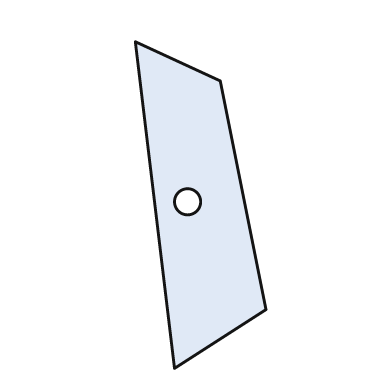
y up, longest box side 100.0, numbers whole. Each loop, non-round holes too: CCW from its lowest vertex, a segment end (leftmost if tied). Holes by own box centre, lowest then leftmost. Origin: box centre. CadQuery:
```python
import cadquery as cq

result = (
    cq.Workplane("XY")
    .moveTo(-8.0, -50.0)
    .lineTo(20.0, -32.0)
    .lineTo(6.0, 38.0)
    .lineTo(-20.0, 50.0)
    .close()
    .moveTo(-4.0, 1.0)
    .circle(4.0)
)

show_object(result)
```